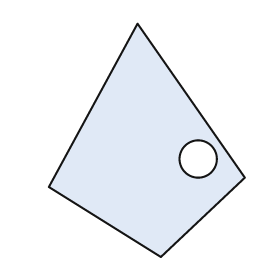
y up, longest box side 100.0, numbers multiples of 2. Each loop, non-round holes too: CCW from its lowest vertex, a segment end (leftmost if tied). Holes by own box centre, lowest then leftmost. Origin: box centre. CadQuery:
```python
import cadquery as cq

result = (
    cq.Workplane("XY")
    .moveTo(6.0, -50.0)
    .lineTo(42.0, -16.0)
    .lineTo(-4.0, 50.0)
    .lineTo(-42.0, -20.0)
    .close()
    .moveTo(22.0, -8.0)
    .circle(8.0)
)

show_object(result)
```